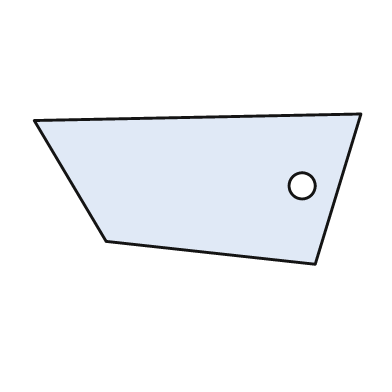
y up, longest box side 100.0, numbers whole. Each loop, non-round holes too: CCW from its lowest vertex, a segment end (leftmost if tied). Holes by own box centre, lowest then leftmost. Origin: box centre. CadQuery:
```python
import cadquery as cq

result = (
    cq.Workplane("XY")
    .moveTo(36.0, -23.0)
    .lineTo(50.0, 23.0)
    .lineTo(-50.0, 21.0)
    .lineTo(-28.0, -16.0)
    .close()
    .moveTo(32.0, 1.0)
    .circle(4.0)
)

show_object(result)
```